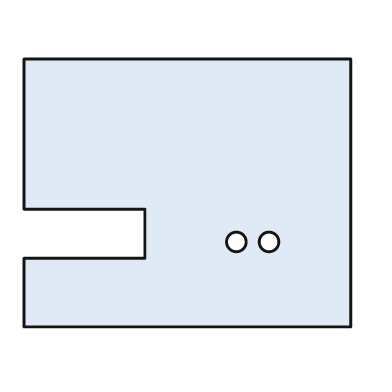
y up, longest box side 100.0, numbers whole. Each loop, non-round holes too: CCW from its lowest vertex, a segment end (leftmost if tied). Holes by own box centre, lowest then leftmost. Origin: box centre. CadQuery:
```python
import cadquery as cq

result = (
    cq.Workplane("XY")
    .moveTo(-50.0, -41.0)
    .lineTo(50.0, -41.0)
    .lineTo(50.0, 41.0)
    .lineTo(-50.0, 41.0)
    .lineTo(-50.0, -5.0)
    .lineTo(-13.0, -5.0)
    .lineTo(-13.0, -20.0)
    .lineTo(-50.0, -20.0)
    .close()
    .moveTo(15.0, -15.0)
    .circle(3.0)
    .moveTo(25.0, -15.0)
    .circle(3.0)
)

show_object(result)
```